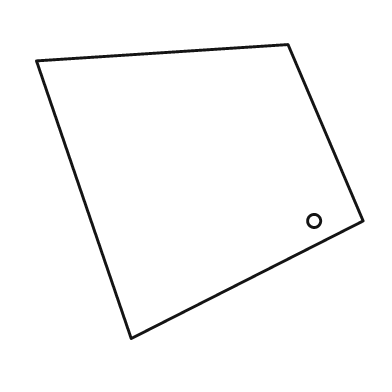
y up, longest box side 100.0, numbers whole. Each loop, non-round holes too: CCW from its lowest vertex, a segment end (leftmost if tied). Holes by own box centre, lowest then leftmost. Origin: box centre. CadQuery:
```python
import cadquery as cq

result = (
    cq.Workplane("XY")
    .moveTo(-21.0, -45.0)
    .lineTo(50.0, -9.0)
    .lineTo(27.0, 45.0)
    .lineTo(-50.0, 40.0)
    .close()
    .moveTo(35.0, -9.0)
    .circle(2.0)
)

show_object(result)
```